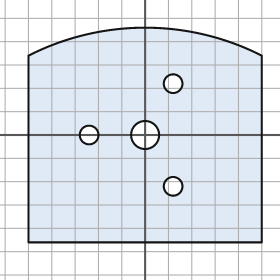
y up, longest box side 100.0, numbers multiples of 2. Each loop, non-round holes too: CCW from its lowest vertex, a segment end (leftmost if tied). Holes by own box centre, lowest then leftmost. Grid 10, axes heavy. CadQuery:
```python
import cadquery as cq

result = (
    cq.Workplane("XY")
    .moveTo(-50.0, -46.0)
    .lineTo(50.0, -46.0)
    .lineTo(50.0, 34.0)
    .threePointArc((0.0, 46.0), (-50.0, 34.0))
    .close()
    .moveTo(12.0, -22.0)
    .circle(4.0)
    .moveTo(-24.0, 0.0)
    .circle(4.0)
    .moveTo(0.0, 0.0)
    .circle(6.0)
    .moveTo(12.0, 22.0)
    .circle(4.0)
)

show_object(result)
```